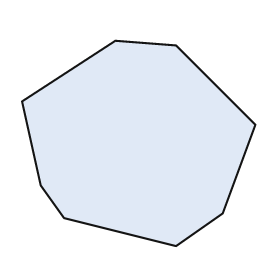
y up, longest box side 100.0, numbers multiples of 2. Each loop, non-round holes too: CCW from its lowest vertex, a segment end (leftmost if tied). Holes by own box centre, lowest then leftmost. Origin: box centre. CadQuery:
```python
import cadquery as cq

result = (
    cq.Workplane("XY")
    .moveTo(16.0, -44.0)
    .lineTo(36.0, -30.0)
    .lineTo(50.0, 8.0)
    .lineTo(16.0, 42.0)
    .lineTo(-10.0, 44.0)
    .lineTo(-50.0, 18.0)
    .lineTo(-42.0, -18.0)
    .lineTo(-32.0, -32.0)
    .close()
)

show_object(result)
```